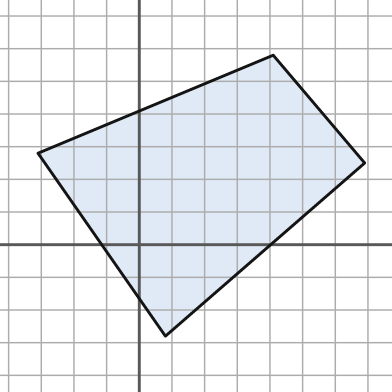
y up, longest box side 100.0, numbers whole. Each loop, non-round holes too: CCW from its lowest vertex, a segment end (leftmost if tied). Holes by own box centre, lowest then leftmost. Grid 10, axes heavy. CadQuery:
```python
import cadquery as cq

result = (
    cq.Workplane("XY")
    .moveTo(8.0, -28.0)
    .lineTo(69.0, 25.0)
    .lineTo(41.0, 58.0)
    .lineTo(-31.0, 28.0)
    .close()
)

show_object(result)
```